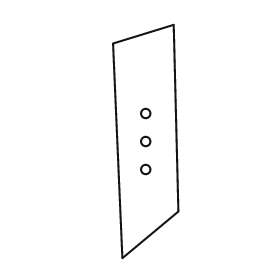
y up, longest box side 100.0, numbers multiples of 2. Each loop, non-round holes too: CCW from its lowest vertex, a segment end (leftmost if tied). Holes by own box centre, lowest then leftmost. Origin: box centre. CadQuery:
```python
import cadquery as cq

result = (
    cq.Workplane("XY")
    .moveTo(-10.0, -50.0)
    .lineTo(14.0, -30.0)
    .lineTo(12.0, 50.0)
    .lineTo(-14.0, 42.0)
    .close()
    .moveTo(0.0, -12.0)
    .circle(2.0)
    .moveTo(0.0, 0.0)
    .circle(2.0)
    .moveTo(0.0, 12.0)
    .circle(2.0)
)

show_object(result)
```